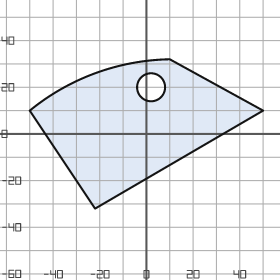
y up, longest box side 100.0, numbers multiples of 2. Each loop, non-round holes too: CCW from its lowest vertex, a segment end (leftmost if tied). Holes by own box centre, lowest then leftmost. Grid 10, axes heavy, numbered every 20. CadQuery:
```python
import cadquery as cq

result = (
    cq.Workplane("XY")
    .moveTo(-22.0, -32.0)
    .lineTo(50.0, 10.0)
    .lineTo(10.0, 32.0)
    .threePointArc((-22.0, 26.0), (-50.0, 10.0))
    .close()
    .moveTo(2.0, 20.0)
    .circle(6.0)
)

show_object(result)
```